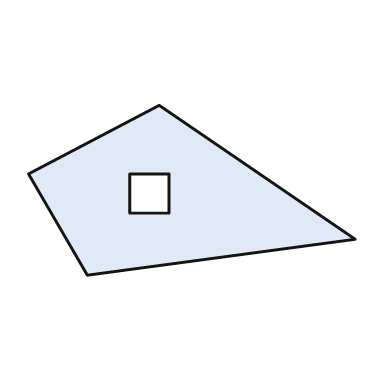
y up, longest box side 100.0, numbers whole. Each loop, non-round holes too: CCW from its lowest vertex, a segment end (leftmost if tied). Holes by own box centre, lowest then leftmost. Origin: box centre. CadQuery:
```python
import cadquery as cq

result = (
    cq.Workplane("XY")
    .moveTo(-32.0, -26.0)
    .lineTo(50.0, -15.0)
    .lineTo(-10.0, 26.0)
    .lineTo(-50.0, 5.0)
    .close()
    .moveTo(-19.0, -7.0)
    .lineTo(-7.0, -7.0)
    .lineTo(-7.0, 5.0)
    .lineTo(-19.0, 5.0)
    .close()
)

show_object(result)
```